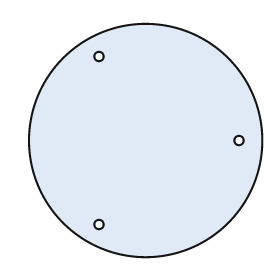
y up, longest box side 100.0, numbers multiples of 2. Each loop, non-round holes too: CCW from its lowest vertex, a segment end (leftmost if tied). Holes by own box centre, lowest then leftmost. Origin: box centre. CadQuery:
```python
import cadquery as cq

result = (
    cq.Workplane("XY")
    .moveTo(0.0, 0.0)
    .circle(50.0)
    .moveTo(-20.0, -36.0)
    .circle(2.0)
    .moveTo(40.0, 0.0)
    .circle(2.0)
    .moveTo(-20.0, 36.0)
    .circle(2.0)
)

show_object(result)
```